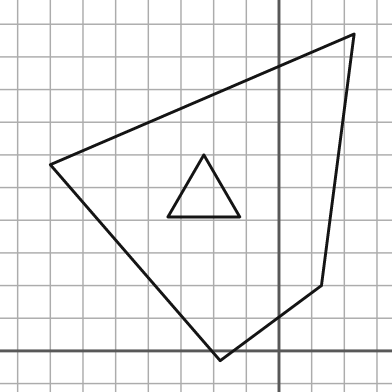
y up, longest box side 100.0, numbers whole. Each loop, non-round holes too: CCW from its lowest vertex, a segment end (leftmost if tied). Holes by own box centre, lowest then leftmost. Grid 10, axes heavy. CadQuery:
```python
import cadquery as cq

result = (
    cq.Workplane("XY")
    .moveTo(-18.0, -3.0)
    .lineTo(13.0, 20.0)
    .lineTo(23.0, 97.0)
    .lineTo(-70.0, 57.0)
    .close()
    .moveTo(-34.0, 41.0)
    .lineTo(-12.0, 41.0)
    .lineTo(-23.0, 60.0)
    .close()
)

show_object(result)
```